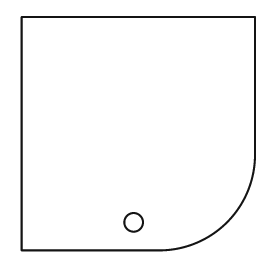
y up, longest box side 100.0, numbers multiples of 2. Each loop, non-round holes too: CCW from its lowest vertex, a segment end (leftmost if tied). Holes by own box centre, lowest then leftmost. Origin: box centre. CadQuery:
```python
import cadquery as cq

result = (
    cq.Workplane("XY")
    .moveTo(-50.0, -50.0)
    .lineTo(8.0, -50.0)
    .threePointArc((38.0, -38.0), (50.0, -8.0))
    .lineTo(50.0, 50.0)
    .lineTo(-50.0, 50.0)
    .close()
    .moveTo(-2.0, -38.0)
    .circle(4.0)
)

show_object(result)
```